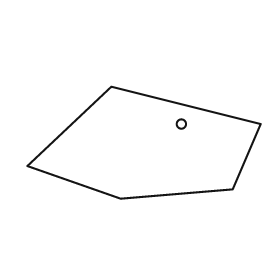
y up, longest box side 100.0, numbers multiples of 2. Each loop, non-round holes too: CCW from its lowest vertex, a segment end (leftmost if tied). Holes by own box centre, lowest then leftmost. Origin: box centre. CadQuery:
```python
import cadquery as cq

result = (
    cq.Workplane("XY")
    .moveTo(-10.0, -24.0)
    .lineTo(38.0, -20.0)
    .lineTo(50.0, 8.0)
    .lineTo(-14.0, 24.0)
    .lineTo(-50.0, -10.0)
    .close()
    .moveTo(16.0, 8.0)
    .circle(2.0)
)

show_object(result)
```